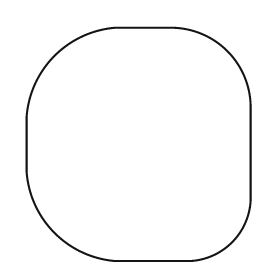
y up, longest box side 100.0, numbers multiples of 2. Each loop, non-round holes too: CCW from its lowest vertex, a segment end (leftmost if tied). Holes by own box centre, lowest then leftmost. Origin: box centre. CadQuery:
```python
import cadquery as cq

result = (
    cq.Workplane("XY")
    .moveTo(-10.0, -50.0)
    .lineTo(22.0, -50.0)
    .threePointArc((40.0, -42.0), (48.0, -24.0))
    .lineTo(48.0, 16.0)
    .threePointArc((38.0, 40.0), (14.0, 50.0))
    .lineTo(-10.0, 50.0)
    .threePointArc((-36.0, 38.0), (-48.0, 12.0))
    .lineTo(-48.0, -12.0)
    .threePointArc((-36.0, -38.0), (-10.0, -50.0))
    .close()
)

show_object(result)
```